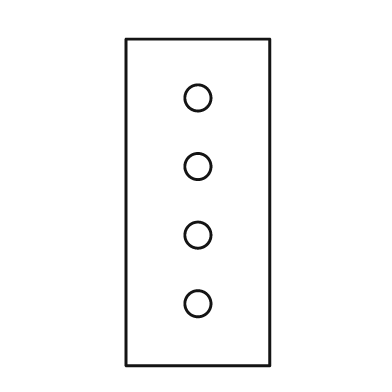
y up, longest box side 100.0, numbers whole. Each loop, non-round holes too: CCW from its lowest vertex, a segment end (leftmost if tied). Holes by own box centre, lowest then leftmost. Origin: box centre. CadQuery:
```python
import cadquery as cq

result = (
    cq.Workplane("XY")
    .moveTo(-22.0, -50.0)
    .lineTo(22.0, -50.0)
    .lineTo(22.0, 50.0)
    .lineTo(-22.0, 50.0)
    .close()
    .moveTo(0.0, -31.0)
    .circle(4.0)
    .moveTo(0.0, -10.0)
    .circle(4.0)
    .moveTo(0.0, 11.0)
    .circle(4.0)
    .moveTo(0.0, 32.0)
    .circle(4.0)
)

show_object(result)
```